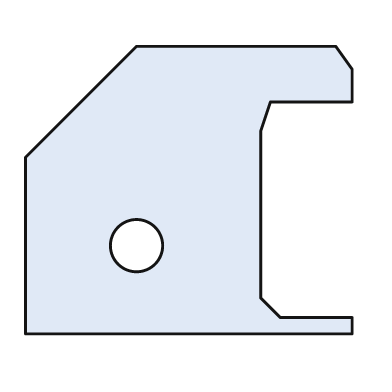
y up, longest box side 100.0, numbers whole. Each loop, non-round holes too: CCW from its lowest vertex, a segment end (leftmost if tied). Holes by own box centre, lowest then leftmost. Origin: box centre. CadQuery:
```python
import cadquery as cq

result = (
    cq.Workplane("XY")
    .moveTo(-50.0, -44.0)
    .lineTo(50.0, -44.0)
    .lineTo(50.0, -39.0)
    .lineTo(28.0, -39.0)
    .lineTo(22.0, -33.0)
    .lineTo(22.0, 18.0)
    .lineTo(25.0, 27.0)
    .lineTo(50.0, 27.0)
    .lineTo(50.0, 37.0)
    .lineTo(45.0, 44.0)
    .lineTo(-16.0, 44.0)
    .lineTo(-50.0, 10.0)
    .close()
    .moveTo(-16.0, -17.0)
    .circle(8.0)
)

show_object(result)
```